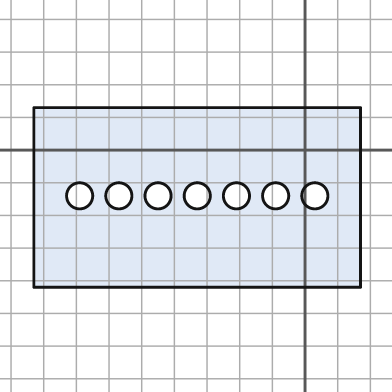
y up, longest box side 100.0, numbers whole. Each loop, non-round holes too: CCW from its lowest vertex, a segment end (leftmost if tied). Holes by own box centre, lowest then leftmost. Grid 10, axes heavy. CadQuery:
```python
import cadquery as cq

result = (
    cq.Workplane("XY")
    .moveTo(-83.0, -42.0)
    .lineTo(17.0, -42.0)
    .lineTo(17.0, 13.0)
    .lineTo(-83.0, 13.0)
    .close()
    .moveTo(-69.0, -14.0)
    .circle(4.0)
    .moveTo(-57.0, -14.0)
    .circle(4.0)
    .moveTo(-45.0, -14.0)
    .circle(4.0)
    .moveTo(-33.0, -14.0)
    .circle(4.0)
    .moveTo(-21.0, -14.0)
    .circle(4.0)
    .moveTo(-9.0, -14.0)
    .circle(4.0)
    .moveTo(3.0, -14.0)
    .circle(4.0)
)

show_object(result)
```